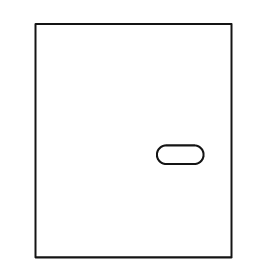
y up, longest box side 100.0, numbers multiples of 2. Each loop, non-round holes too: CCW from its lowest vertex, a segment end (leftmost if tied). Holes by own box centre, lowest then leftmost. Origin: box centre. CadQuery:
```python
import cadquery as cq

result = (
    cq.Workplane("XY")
    .moveTo(-42.0, -50.0)
    .lineTo(42.0, -50.0)
    .lineTo(42.0, 50.0)
    .lineTo(-42.0, 50.0)
    .close()
    .moveTo(14.0, -10.0)
    .lineTo(26.0, -10.0)
    .threePointArc((30.0, -6.0), (26.0, -2.0))
    .lineTo(14.0, -2.0)
    .threePointArc((10.0, -6.0), (14.0, -10.0))
    .close()
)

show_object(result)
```